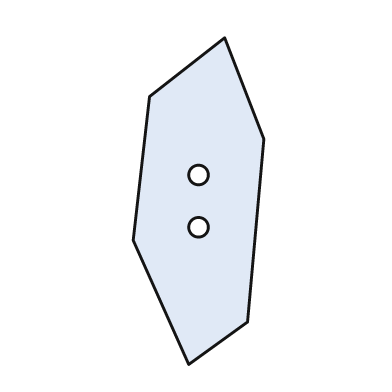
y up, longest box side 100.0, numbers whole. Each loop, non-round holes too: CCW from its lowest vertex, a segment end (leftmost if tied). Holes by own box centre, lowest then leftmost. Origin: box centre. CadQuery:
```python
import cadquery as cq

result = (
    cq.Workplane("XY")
    .moveTo(-3.0, -50.0)
    .lineTo(15.0, -37.0)
    .lineTo(20.0, 19.0)
    .lineTo(8.0, 50.0)
    .lineTo(-15.0, 32.0)
    .lineTo(-20.0, -12.0)
    .close()
    .moveTo(0.0, -8.0)
    .circle(3.0)
    .moveTo(0.0, 8.0)
    .circle(3.0)
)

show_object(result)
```